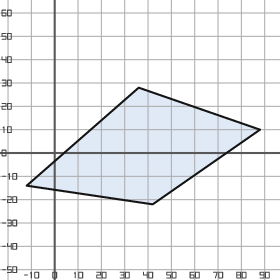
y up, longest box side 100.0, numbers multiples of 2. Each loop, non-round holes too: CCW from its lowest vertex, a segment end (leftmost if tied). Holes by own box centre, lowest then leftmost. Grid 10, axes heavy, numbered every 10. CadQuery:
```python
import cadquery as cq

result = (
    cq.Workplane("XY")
    .moveTo(42.0, -22.0)
    .lineTo(88.0, 10.0)
    .lineTo(36.0, 28.0)
    .lineTo(-12.0, -14.0)
    .close()
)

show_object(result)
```